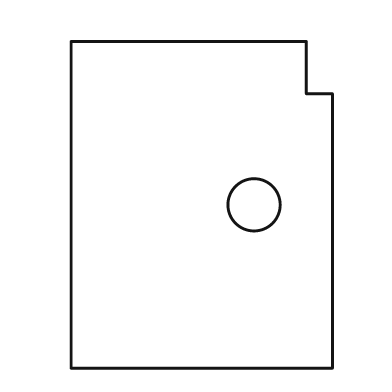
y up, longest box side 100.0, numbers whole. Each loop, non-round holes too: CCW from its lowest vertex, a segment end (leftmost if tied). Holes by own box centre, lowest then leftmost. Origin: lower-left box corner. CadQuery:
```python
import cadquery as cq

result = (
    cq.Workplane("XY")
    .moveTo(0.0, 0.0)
    .lineTo(80.0, 0.0)
    .lineTo(80.0, 84.0)
    .lineTo(72.0, 84.0)
    .lineTo(72.0, 100.0)
    .lineTo(0.0, 100.0)
    .close()
    .moveTo(56.0, 50.0)
    .circle(8.0)
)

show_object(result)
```